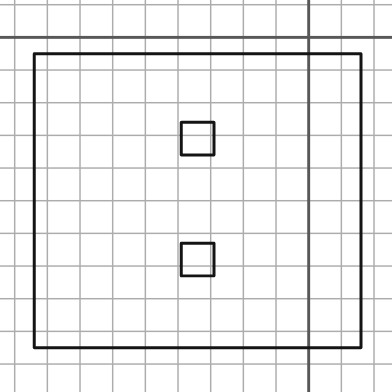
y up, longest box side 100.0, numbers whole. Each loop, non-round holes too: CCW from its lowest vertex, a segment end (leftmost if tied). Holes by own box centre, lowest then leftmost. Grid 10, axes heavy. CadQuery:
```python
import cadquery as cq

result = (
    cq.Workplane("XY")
    .moveTo(-84.0, -95.0)
    .lineTo(16.0, -95.0)
    .lineTo(16.0, -5.0)
    .lineTo(-84.0, -5.0)
    .close()
    .moveTo(-39.0, -73.0)
    .lineTo(-29.0, -73.0)
    .lineTo(-29.0, -63.0)
    .lineTo(-39.0, -63.0)
    .close()
    .moveTo(-39.0, -36.0)
    .lineTo(-29.0, -36.0)
    .lineTo(-29.0, -26.0)
    .lineTo(-39.0, -26.0)
    .close()
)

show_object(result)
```